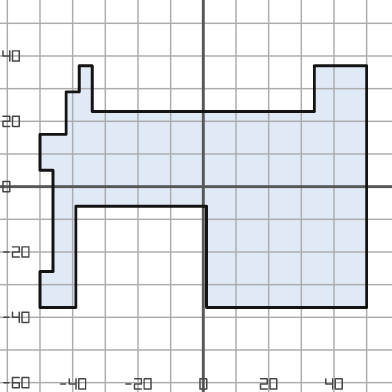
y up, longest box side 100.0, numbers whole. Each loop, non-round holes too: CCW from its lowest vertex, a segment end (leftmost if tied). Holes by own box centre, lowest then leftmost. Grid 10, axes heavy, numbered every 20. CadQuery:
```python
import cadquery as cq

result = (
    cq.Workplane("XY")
    .moveTo(-50.0, -37.0)
    .lineTo(-39.0, -37.0)
    .lineTo(-39.0, -6.0)
    .lineTo(1.0, -6.0)
    .lineTo(1.0, -37.0)
    .lineTo(50.0, -37.0)
    .lineTo(50.0, 37.0)
    .lineTo(34.0, 37.0)
    .lineTo(34.0, 23.0)
    .lineTo(-34.0, 23.0)
    .lineTo(-34.0, 37.0)
    .lineTo(-38.0, 37.0)
    .lineTo(-38.0, 29.0)
    .lineTo(-42.0, 29.0)
    .lineTo(-42.0, 16.0)
    .lineTo(-50.0, 16.0)
    .lineTo(-50.0, 5.0)
    .lineTo(-46.0, 5.0)
    .lineTo(-46.0, -26.0)
    .lineTo(-50.0, -26.0)
    .close()
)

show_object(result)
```